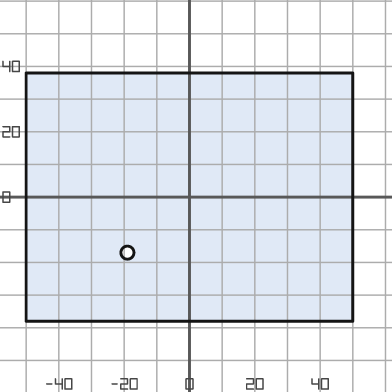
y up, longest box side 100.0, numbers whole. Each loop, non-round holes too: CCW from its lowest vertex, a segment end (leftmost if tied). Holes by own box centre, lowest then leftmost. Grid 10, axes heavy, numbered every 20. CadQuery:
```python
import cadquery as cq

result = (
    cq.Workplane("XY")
    .moveTo(-50.0, -38.0)
    .lineTo(50.0, -38.0)
    .lineTo(50.0, 38.0)
    .lineTo(-50.0, 38.0)
    .close()
    .moveTo(-19.0, -17.0)
    .circle(2.0)
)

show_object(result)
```